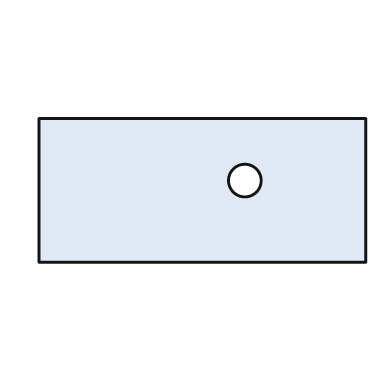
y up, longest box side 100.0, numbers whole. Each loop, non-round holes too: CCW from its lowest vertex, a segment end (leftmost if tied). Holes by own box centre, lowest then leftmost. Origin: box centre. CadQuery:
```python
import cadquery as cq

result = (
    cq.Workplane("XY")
    .moveTo(-50.0, -22.0)
    .lineTo(50.0, -22.0)
    .lineTo(50.0, 22.0)
    .lineTo(-50.0, 22.0)
    .close()
    .moveTo(13.0, 3.0)
    .circle(5.0)
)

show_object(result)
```